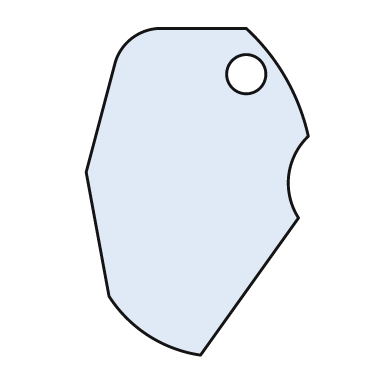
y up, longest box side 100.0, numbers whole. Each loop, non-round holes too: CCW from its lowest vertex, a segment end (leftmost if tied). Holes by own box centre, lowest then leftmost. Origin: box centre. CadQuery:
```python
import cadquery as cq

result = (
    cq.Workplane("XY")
    .moveTo(1.0, -50.0)
    .lineTo(31.0, -8.0)
    .threePointArc((28.0, 5.0), (34.0, 17.0))
    .threePointArc((27.0, 35.0), (15.0, 50.0))
    .lineTo(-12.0, 50.0)
    .threePointArc((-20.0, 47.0), (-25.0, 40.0))
    .lineTo(-34.0, 6.0)
    .lineTo(-27.0, -32.0)
    .threePointArc((-15.0, -44.0), (1.0, -50.0))
    .close()
    .moveTo(15.0, 36.0)
    .circle(6.0)
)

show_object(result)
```